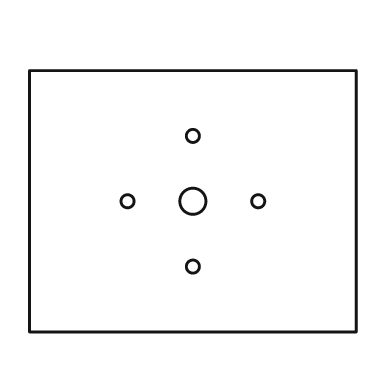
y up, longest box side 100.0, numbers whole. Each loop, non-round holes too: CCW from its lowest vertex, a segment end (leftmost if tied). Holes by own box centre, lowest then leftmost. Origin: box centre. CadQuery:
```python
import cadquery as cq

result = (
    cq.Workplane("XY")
    .moveTo(-50.0, -40.0)
    .lineTo(50.0, -40.0)
    .lineTo(50.0, 40.0)
    .lineTo(-50.0, 40.0)
    .close()
    .moveTo(0.0, -20.0)
    .circle(2.0)
    .moveTo(-20.0, 0.0)
    .circle(2.0)
    .moveTo(0.0, 0.0)
    .circle(4.0)
    .moveTo(20.0, 0.0)
    .circle(2.0)
    .moveTo(0.0, 20.0)
    .circle(2.0)
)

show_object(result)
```